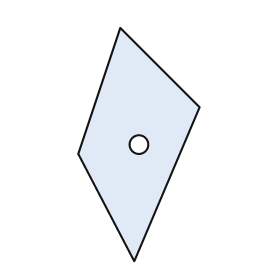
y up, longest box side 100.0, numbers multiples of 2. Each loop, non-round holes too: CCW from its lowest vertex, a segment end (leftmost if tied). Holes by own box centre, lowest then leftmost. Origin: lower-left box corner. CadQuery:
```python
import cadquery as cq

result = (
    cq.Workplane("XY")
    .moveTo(24.0, 0.0)
    .lineTo(52.0, 66.0)
    .lineTo(18.0, 100.0)
    .lineTo(0.0, 46.0)
    .close()
    .moveTo(26.0, 50.0)
    .circle(4.0)
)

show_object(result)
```